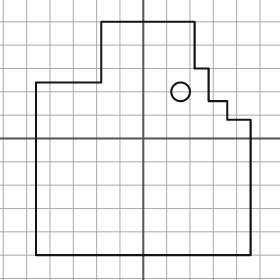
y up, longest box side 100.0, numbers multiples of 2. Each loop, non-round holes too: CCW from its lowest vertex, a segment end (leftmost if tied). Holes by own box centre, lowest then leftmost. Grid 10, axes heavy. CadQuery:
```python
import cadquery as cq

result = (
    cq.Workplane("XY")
    .moveTo(-46.0, -50.0)
    .lineTo(46.0, -50.0)
    .lineTo(46.0, 8.0)
    .lineTo(36.0, 8.0)
    .lineTo(36.0, 16.0)
    .lineTo(28.0, 16.0)
    .lineTo(28.0, 30.0)
    .lineTo(22.0, 30.0)
    .lineTo(22.0, 50.0)
    .lineTo(-18.0, 50.0)
    .lineTo(-18.0, 24.0)
    .lineTo(-46.0, 24.0)
    .close()
    .moveTo(16.0, 20.0)
    .circle(4.0)
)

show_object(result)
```